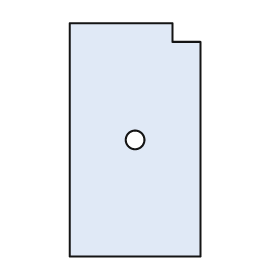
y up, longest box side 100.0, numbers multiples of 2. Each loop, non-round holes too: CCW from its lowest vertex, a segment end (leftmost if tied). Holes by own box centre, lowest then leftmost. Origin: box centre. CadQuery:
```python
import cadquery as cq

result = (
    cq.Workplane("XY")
    .moveTo(-28.0, -50.0)
    .lineTo(28.0, -50.0)
    .lineTo(28.0, 42.0)
    .lineTo(16.0, 42.0)
    .lineTo(16.0, 50.0)
    .lineTo(-28.0, 50.0)
    .close()
    .moveTo(0.0, 0.0)
    .circle(4.0)
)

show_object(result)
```